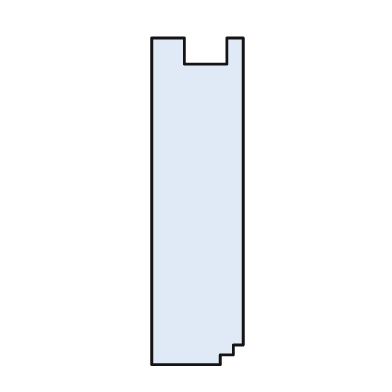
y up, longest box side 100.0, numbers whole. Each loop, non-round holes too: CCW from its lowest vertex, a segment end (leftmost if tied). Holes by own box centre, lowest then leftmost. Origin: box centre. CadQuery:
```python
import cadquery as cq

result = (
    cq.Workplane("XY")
    .moveTo(-14.0, -50.0)
    .lineTo(7.0, -50.0)
    .lineTo(7.0, -47.0)
    .lineTo(11.0, -47.0)
    .lineTo(11.0, -44.0)
    .lineTo(14.0, -44.0)
    .lineTo(14.0, 50.0)
    .lineTo(9.0, 50.0)
    .lineTo(9.0, 42.0)
    .lineTo(-4.0, 42.0)
    .lineTo(-4.0, 50.0)
    .lineTo(-14.0, 50.0)
    .close()
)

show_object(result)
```